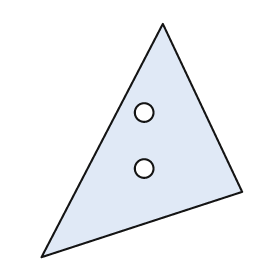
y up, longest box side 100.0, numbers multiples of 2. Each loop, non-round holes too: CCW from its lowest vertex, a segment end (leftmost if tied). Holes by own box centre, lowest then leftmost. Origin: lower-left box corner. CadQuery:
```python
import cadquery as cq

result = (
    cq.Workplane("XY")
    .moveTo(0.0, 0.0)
    .lineTo(86.0, 28.0)
    .lineTo(52.0, 100.0)
    .close()
    .moveTo(44.0, 38.0)
    .circle(4.0)
    .moveTo(44.0, 62.0)
    .circle(4.0)
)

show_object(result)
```